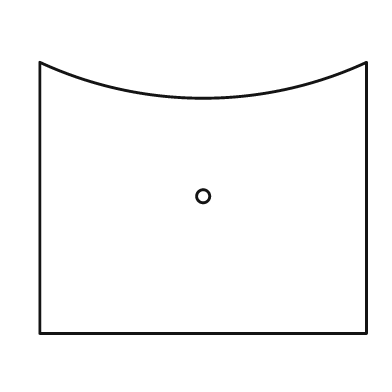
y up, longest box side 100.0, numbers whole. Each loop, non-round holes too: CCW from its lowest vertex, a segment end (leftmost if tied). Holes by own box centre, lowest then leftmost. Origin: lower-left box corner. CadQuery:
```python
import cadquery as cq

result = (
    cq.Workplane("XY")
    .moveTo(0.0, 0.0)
    .lineTo(100.0, 0.0)
    .lineTo(100.0, 83.0)
    .threePointArc((50.0, 72.0), (0.0, 83.0))
    .close()
    .moveTo(50.0, 42.0)
    .circle(2.0)
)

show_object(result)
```